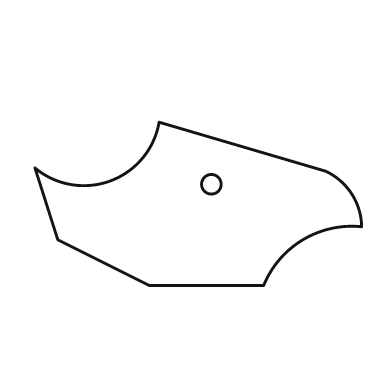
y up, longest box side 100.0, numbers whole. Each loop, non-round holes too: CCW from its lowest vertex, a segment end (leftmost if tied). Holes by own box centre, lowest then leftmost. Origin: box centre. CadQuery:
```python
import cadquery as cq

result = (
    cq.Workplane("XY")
    .moveTo(-15.0, -25.0)
    .lineTo(20.0, -25.0)
    .threePointArc((32.0, -11.0), (50.0, -7.0))
    .threePointArc((47.0, 3.0), (39.0, 10.0))
    .lineTo(-12.0, 25.0)
    .threePointArc((-27.0, 7.0), (-50.0, 11.0))
    .lineTo(-43.0, -11.0)
    .close()
    .moveTo(4.0, 6.0)
    .circle(3.0)
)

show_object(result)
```